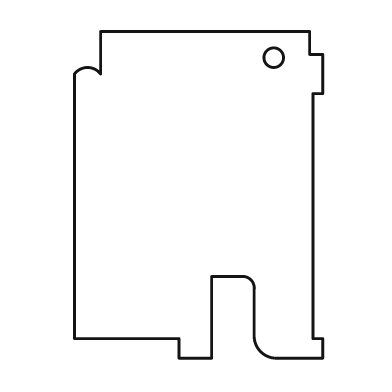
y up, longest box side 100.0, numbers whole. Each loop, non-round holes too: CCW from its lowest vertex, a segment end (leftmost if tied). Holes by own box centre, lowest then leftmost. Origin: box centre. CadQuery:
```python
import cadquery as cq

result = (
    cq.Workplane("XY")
    .moveTo(-6.0, -50.0)
    .lineTo(4.0, -50.0)
    .lineTo(4.0, -25.0)
    .lineTo(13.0, -25.0)
    .threePointArc((16.0, -26.0), (17.0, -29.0))
    .lineTo(17.0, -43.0)
    .threePointArc((19.0, -48.0), (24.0, -50.0))
    .lineTo(38.0, -50.0)
    .lineTo(38.0, -44.0)
    .lineTo(35.0, -44.0)
    .lineTo(35.0, 31.0)
    .lineTo(38.0, 31.0)
    .lineTo(38.0, 43.0)
    .lineTo(34.0, 43.0)
    .lineTo(34.0, 50.0)
    .lineTo(-30.0, 50.0)
    .lineTo(-30.0, 37.0)
    .threePointArc((-34.0, 39.0), (-38.0, 37.0))
    .lineTo(-38.0, -44.0)
    .lineTo(-6.0, -44.0)
    .close()
    .moveTo(23.0, 42.0)
    .circle(3.0)
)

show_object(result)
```